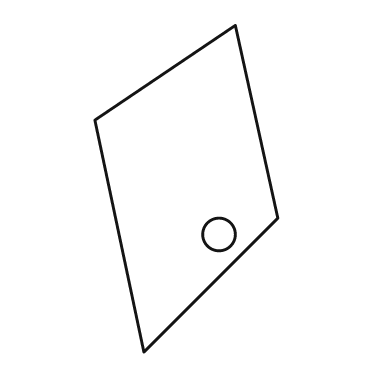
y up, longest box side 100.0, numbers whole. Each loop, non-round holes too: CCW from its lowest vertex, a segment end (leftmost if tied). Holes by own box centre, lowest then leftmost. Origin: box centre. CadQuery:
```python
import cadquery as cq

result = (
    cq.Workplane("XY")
    .moveTo(-13.0, -50.0)
    .lineTo(28.0, -9.0)
    .lineTo(15.0, 50.0)
    .lineTo(-28.0, 21.0)
    .close()
    .moveTo(10.0, -14.0)
    .circle(5.0)
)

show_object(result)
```